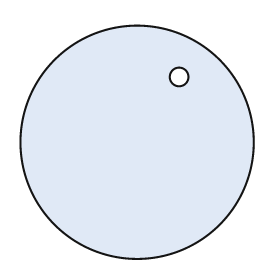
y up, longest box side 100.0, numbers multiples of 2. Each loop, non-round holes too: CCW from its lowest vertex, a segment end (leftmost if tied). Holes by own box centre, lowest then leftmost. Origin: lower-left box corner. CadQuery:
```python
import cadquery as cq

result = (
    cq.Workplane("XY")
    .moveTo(50.0, 50.0)
    .circle(50.0)
    .moveTo(68.0, 78.0)
    .circle(4.0)
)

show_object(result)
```